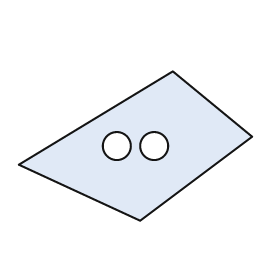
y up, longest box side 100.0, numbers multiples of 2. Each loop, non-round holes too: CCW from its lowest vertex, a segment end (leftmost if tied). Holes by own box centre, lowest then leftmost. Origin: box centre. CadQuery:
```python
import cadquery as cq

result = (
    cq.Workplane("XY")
    .moveTo(2.0, -32.0)
    .lineTo(50.0, 4.0)
    .lineTo(16.0, 32.0)
    .lineTo(-50.0, -8.0)
    .close()
    .moveTo(-8.0, 0.0)
    .circle(6.0)
    .moveTo(8.0, 0.0)
    .circle(6.0)
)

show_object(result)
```